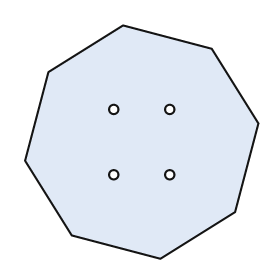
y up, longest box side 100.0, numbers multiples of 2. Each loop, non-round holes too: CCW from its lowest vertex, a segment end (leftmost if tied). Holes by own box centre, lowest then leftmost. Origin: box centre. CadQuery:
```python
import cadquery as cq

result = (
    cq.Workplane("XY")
    .moveTo(8.0, -50.0)
    .lineTo(40.0, -30.0)
    .lineTo(50.0, 8.0)
    .lineTo(30.0, 40.0)
    .lineTo(-8.0, 50.0)
    .lineTo(-40.0, 30.0)
    .lineTo(-50.0, -8.0)
    .lineTo(-30.0, -40.0)
    .close()
    .moveTo(-12.0, -14.0)
    .circle(2.0)
    .moveTo(12.0, -14.0)
    .circle(2.0)
    .moveTo(-12.0, 14.0)
    .circle(2.0)
    .moveTo(12.0, 14.0)
    .circle(2.0)
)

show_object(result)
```